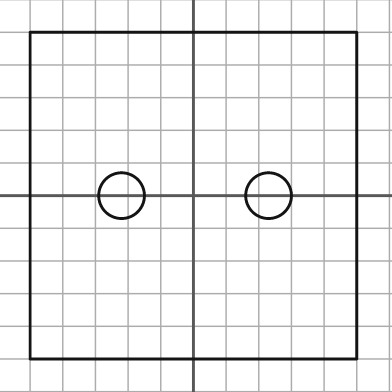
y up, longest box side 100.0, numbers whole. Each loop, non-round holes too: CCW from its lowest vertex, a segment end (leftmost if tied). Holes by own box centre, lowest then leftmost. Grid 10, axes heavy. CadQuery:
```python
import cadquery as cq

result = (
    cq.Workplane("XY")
    .moveTo(-50.0, -50.0)
    .lineTo(50.0, -50.0)
    .lineTo(50.0, 50.0)
    .lineTo(-50.0, 50.0)
    .close()
    .moveTo(-22.0, 0.0)
    .circle(7.0)
    .moveTo(23.0, 0.0)
    .circle(7.0)
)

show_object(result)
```